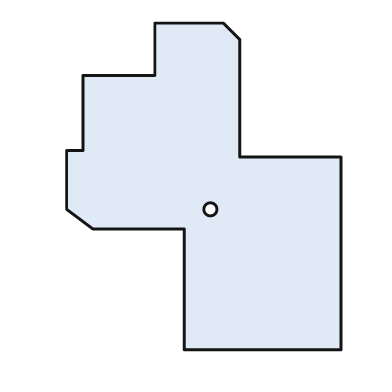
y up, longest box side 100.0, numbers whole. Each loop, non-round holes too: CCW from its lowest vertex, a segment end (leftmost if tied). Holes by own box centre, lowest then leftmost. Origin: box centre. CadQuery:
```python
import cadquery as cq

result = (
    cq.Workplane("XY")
    .moveTo(-6.0, -50.0)
    .lineTo(42.0, -50.0)
    .lineTo(42.0, 9.0)
    .lineTo(11.0, 9.0)
    .lineTo(11.0, 45.0)
    .lineTo(6.0, 50.0)
    .lineTo(-15.0, 50.0)
    .lineTo(-15.0, 34.0)
    .lineTo(-37.0, 34.0)
    .lineTo(-37.0, 11.0)
    .lineTo(-42.0, 11.0)
    .lineTo(-42.0, -7.0)
    .lineTo(-34.0, -13.0)
    .lineTo(-6.0, -13.0)
    .close()
    .moveTo(2.0, -7.0)
    .circle(2.0)
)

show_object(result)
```